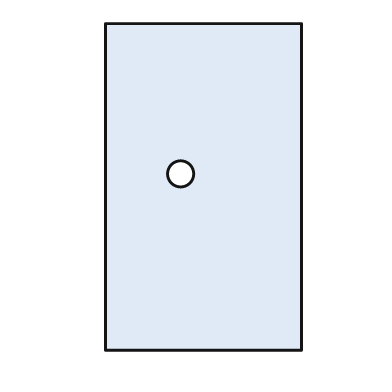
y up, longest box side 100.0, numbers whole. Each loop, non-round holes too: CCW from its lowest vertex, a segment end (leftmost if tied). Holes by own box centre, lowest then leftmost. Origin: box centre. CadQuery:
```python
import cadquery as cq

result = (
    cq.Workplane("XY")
    .moveTo(-30.0, -50.0)
    .lineTo(30.0, -50.0)
    .lineTo(30.0, 50.0)
    .lineTo(-30.0, 50.0)
    .close()
    .moveTo(-7.0, 4.0)
    .circle(4.0)
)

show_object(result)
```